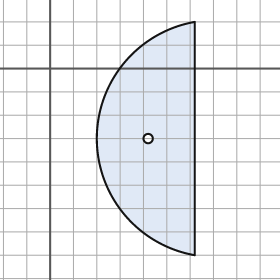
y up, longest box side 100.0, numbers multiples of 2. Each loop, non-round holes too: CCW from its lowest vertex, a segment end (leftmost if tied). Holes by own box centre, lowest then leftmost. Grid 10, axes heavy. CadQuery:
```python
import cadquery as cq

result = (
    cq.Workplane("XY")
    .moveTo(62.0, -80.0)
    .lineTo(62.0, 20.0)
    .threePointArc((20.0, -30.0), (62.0, -80.0))
    .close()
    .moveTo(42.0, -30.0)
    .circle(2.0)
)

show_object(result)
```